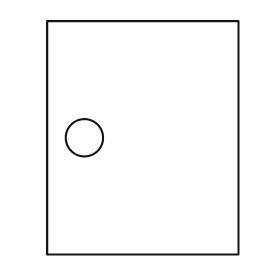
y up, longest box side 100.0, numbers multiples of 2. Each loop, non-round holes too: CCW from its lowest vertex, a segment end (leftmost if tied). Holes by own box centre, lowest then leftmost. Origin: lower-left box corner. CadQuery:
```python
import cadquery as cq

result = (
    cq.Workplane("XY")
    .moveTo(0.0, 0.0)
    .lineTo(82.0, 0.0)
    .lineTo(82.0, 100.0)
    .lineTo(0.0, 100.0)
    .close()
    .moveTo(16.0, 50.0)
    .circle(8.0)
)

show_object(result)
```